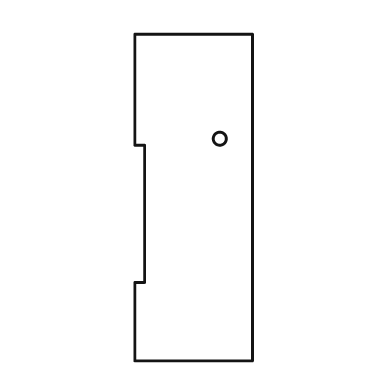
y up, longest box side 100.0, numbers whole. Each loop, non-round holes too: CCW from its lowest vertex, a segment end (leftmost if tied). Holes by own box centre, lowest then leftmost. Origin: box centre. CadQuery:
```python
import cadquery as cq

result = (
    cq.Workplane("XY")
    .moveTo(-18.0, -50.0)
    .lineTo(18.0, -50.0)
    .lineTo(18.0, 50.0)
    .lineTo(-18.0, 50.0)
    .lineTo(-18.0, 16.0)
    .lineTo(-15.0, 16.0)
    .lineTo(-15.0, -26.0)
    .lineTo(-18.0, -26.0)
    .close()
    .moveTo(8.0, 18.0)
    .circle(2.0)
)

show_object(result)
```